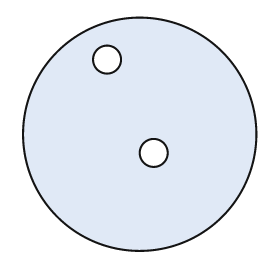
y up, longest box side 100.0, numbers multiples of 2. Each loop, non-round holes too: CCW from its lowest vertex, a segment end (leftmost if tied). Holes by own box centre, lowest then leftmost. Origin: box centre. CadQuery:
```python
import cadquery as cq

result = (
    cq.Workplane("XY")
    .moveTo(0.0, 0.0)
    .circle(50.0)
    .moveTo(6.0, -8.0)
    .circle(6.0)
    .moveTo(-14.0, 32.0)
    .circle(6.0)
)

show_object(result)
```